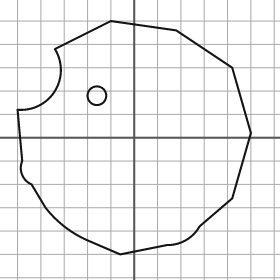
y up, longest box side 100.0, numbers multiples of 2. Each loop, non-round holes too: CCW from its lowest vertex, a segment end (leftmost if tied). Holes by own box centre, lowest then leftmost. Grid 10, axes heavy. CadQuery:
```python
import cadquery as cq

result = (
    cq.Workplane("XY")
    .moveTo(-6.0, -50.0)
    .lineTo(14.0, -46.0)
    .threePointArc((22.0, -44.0), (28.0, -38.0))
    .lineTo(42.0, -26.0)
    .lineTo(50.0, 2.0)
    .lineTo(42.0, 30.0)
    .lineTo(18.0, 46.0)
    .lineTo(-10.0, 50.0)
    .lineTo(-34.0, 38.0)
    .threePointArc((-34.0, 20.0), (-50.0, 12.0))
    .lineTo(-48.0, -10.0)
    .threePointArc((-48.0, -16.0), (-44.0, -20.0))
    .lineTo(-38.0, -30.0)
    .threePointArc((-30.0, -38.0), (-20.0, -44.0))
    .close()
    .moveTo(-16.0, 18.0)
    .circle(4.0)
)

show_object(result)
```